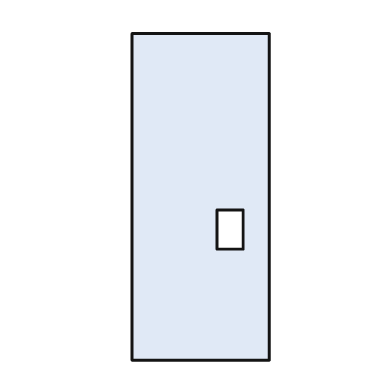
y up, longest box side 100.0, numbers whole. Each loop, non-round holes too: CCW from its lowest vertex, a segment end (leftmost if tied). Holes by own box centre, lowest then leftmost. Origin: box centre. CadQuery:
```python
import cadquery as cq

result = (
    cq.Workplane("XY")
    .moveTo(-21.0, -50.0)
    .lineTo(21.0, -50.0)
    .lineTo(21.0, 50.0)
    .lineTo(-21.0, 50.0)
    .close()
    .moveTo(5.0, -16.0)
    .lineTo(13.0, -16.0)
    .lineTo(13.0, -4.0)
    .lineTo(5.0, -4.0)
    .close()
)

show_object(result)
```